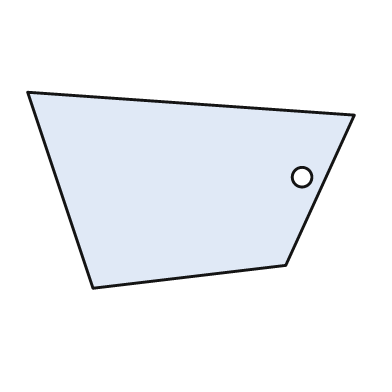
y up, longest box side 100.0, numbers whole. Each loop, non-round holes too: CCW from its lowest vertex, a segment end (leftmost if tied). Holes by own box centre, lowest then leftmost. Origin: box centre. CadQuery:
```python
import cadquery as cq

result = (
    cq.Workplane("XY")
    .moveTo(-30.0, -30.0)
    .lineTo(29.0, -23.0)
    .lineTo(50.0, 23.0)
    .lineTo(-50.0, 30.0)
    .close()
    .moveTo(34.0, 4.0)
    .circle(3.0)
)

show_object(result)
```